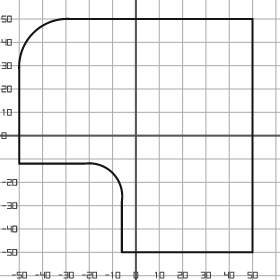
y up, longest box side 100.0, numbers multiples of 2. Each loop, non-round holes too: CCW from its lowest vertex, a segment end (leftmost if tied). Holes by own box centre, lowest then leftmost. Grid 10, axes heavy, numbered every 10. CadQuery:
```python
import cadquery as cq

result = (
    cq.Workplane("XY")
    .moveTo(-6.0, -50.0)
    .lineTo(50.0, -50.0)
    .lineTo(50.0, 50.0)
    .lineTo(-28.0, 50.0)
    .threePointArc((-44.0, 44.0), (-50.0, 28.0))
    .lineTo(-50.0, -12.0)
    .lineTo(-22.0, -12.0)
    .threePointArc((-10.0, -16.0), (-6.0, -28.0))
    .close()
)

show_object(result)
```